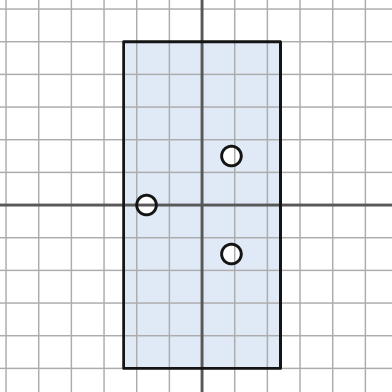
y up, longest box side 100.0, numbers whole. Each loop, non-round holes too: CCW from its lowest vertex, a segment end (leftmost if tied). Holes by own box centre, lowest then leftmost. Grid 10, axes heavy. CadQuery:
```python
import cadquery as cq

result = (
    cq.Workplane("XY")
    .moveTo(-24.0, -50.0)
    .lineTo(24.0, -50.0)
    .lineTo(24.0, 50.0)
    .lineTo(-24.0, 50.0)
    .close()
    .moveTo(9.0, -15.0)
    .circle(3.0)
    .moveTo(-17.0, 0.0)
    .circle(3.0)
    .moveTo(9.0, 15.0)
    .circle(3.0)
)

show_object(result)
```